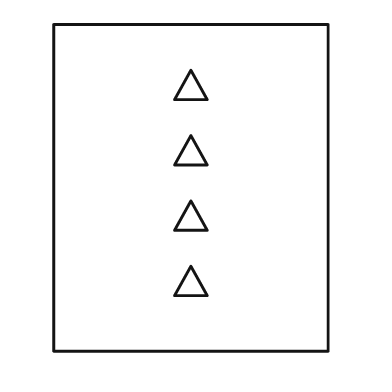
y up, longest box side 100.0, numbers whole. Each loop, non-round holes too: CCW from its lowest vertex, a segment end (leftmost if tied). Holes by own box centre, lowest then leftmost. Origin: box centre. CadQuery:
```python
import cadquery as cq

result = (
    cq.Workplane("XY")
    .moveTo(-42.0, -50.0)
    .lineTo(42.0, -50.0)
    .lineTo(42.0, 50.0)
    .lineTo(-42.0, 50.0)
    .close()
    .moveTo(-5.0, -33.0)
    .lineTo(5.0, -33.0)
    .lineTo(0.0, -24.0)
    .close()
    .moveTo(-5.0, -13.0)
    .lineTo(5.0, -13.0)
    .lineTo(0.0, -4.0)
    .close()
    .moveTo(-5.0, 7.0)
    .lineTo(5.0, 7.0)
    .lineTo(0.0, 16.0)
    .close()
    .moveTo(-5.0, 27.0)
    .lineTo(5.0, 27.0)
    .lineTo(0.0, 36.0)
    .close()
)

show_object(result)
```